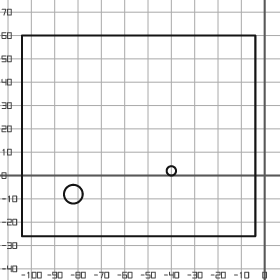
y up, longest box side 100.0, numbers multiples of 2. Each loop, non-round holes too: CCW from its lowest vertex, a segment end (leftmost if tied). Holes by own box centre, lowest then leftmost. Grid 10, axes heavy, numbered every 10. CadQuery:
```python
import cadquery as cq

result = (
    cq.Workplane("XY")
    .moveTo(-104.0, -26.0)
    .lineTo(-4.0, -26.0)
    .lineTo(-4.0, 60.0)
    .lineTo(-104.0, 60.0)
    .close()
    .moveTo(-82.0, -8.0)
    .circle(4.0)
    .moveTo(-40.0, 2.0)
    .circle(2.0)
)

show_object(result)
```